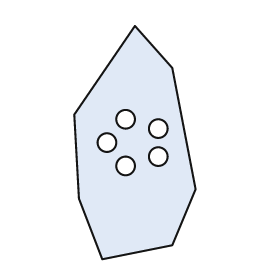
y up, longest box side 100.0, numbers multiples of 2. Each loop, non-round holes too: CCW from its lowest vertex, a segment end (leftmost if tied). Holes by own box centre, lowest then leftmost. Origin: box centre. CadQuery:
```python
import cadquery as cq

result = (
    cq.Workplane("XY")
    .moveTo(-14.0, -50.0)
    .lineTo(16.0, -44.0)
    .lineTo(26.0, -20.0)
    .lineTo(16.0, 32.0)
    .lineTo(0.0, 50.0)
    .lineTo(-26.0, 12.0)
    .lineTo(-24.0, -24.0)
    .close()
    .moveTo(-4.0, -10.0)
    .circle(4.0)
    .moveTo(10.0, -6.0)
    .circle(4.0)
    .moveTo(-12.0, 0.0)
    .circle(4.0)
    .moveTo(10.0, 6.0)
    .circle(4.0)
    .moveTo(-4.0, 10.0)
    .circle(4.0)
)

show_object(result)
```